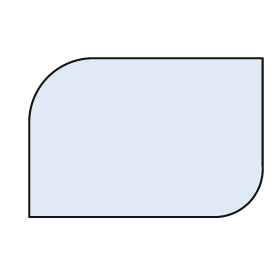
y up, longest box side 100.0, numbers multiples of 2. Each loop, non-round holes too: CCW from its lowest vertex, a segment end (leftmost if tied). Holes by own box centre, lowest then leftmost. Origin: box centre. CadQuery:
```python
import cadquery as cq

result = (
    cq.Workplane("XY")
    .moveTo(-50.0, -34.0)
    .lineTo(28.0, -34.0)
    .threePointArc((44.0, -28.0), (50.0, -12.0))
    .lineTo(50.0, 34.0)
    .lineTo(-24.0, 34.0)
    .threePointArc((-42.0, 26.0), (-50.0, 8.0))
    .close()
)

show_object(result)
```